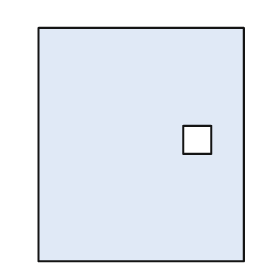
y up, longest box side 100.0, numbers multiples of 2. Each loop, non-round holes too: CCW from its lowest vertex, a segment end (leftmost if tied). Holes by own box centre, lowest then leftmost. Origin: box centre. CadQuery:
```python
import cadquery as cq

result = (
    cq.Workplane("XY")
    .moveTo(-44.0, -50.0)
    .lineTo(44.0, -50.0)
    .lineTo(44.0, 50.0)
    .lineTo(-44.0, 50.0)
    .close()
    .moveTo(18.0, -4.0)
    .lineTo(30.0, -4.0)
    .lineTo(30.0, 8.0)
    .lineTo(18.0, 8.0)
    .close()
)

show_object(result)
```